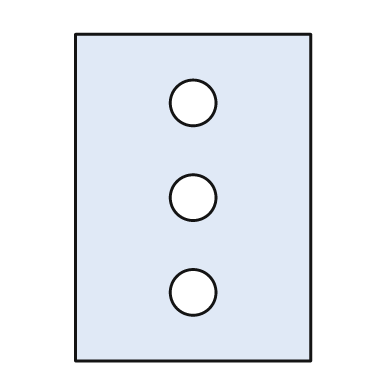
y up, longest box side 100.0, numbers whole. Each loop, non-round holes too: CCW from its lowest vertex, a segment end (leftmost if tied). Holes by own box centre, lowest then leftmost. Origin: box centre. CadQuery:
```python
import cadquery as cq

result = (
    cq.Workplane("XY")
    .moveTo(-36.0, -50.0)
    .lineTo(36.0, -50.0)
    .lineTo(36.0, 50.0)
    .lineTo(-36.0, 50.0)
    .close()
    .moveTo(0.0, -29.0)
    .circle(7.0)
    .moveTo(0.0, 0.0)
    .circle(7.0)
    .moveTo(0.0, 29.0)
    .circle(7.0)
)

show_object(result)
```